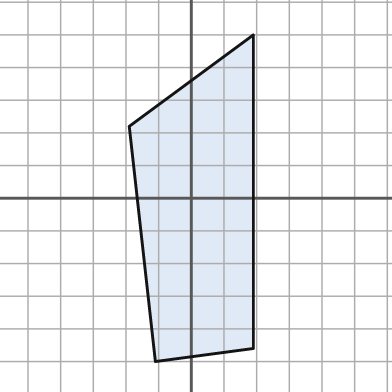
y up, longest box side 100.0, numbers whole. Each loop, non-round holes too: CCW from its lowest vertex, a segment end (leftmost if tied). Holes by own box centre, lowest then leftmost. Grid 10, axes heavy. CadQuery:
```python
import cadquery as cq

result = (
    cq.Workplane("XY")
    .moveTo(-11.0, -50.0)
    .lineTo(19.0, -46.0)
    .lineTo(19.0, 50.0)
    .lineTo(-19.0, 22.0)
    .close()
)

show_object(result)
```